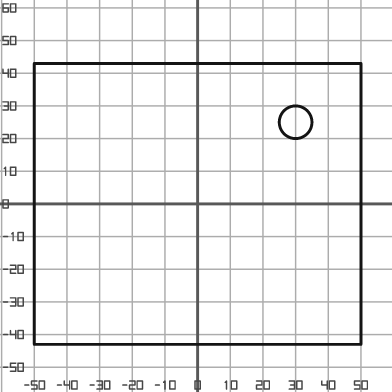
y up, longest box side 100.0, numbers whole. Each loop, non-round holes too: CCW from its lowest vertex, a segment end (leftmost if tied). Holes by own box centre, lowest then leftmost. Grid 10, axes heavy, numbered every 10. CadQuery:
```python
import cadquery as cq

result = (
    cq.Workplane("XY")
    .moveTo(-50.0, -43.0)
    .lineTo(50.0, -43.0)
    .lineTo(50.0, 43.0)
    .lineTo(-50.0, 43.0)
    .close()
    .moveTo(30.0, 25.0)
    .circle(5.0)
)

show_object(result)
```